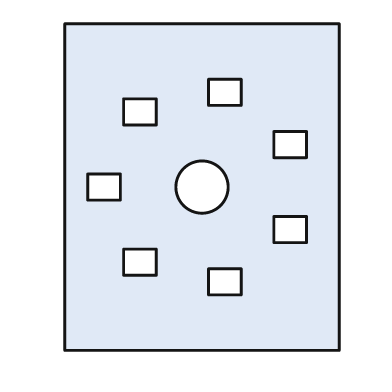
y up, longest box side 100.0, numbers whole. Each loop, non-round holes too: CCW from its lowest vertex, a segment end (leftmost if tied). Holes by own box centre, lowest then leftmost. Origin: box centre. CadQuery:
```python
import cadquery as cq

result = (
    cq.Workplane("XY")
    .moveTo(-42.0, -50.0)
    .lineTo(42.0, -50.0)
    .lineTo(42.0, 50.0)
    .lineTo(-42.0, 50.0)
    .close()
    .moveTo(2.0, -33.0)
    .lineTo(12.0, -33.0)
    .lineTo(12.0, -25.0)
    .lineTo(2.0, -25.0)
    .close()
    .moveTo(-24.0, -27.0)
    .lineTo(-14.0, -27.0)
    .lineTo(-14.0, -19.0)
    .lineTo(-24.0, -19.0)
    .close()
    .moveTo(22.0, -17.0)
    .lineTo(32.0, -17.0)
    .lineTo(32.0, -9.0)
    .lineTo(22.0, -9.0)
    .close()
    .moveTo(-35.0, -4.0)
    .lineTo(-25.0, -4.0)
    .lineTo(-25.0, 4.0)
    .lineTo(-35.0, 4.0)
    .close()
    .moveTo(0.0, 0.0)
    .circle(8.0)
    .moveTo(22.0, 9.0)
    .lineTo(32.0, 9.0)
    .lineTo(32.0, 17.0)
    .lineTo(22.0, 17.0)
    .close()
    .moveTo(-24.0, 19.0)
    .lineTo(-14.0, 19.0)
    .lineTo(-14.0, 27.0)
    .lineTo(-24.0, 27.0)
    .close()
    .moveTo(2.0, 25.0)
    .lineTo(12.0, 25.0)
    .lineTo(12.0, 33.0)
    .lineTo(2.0, 33.0)
    .close()
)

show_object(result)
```